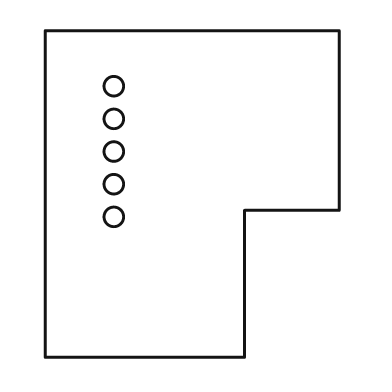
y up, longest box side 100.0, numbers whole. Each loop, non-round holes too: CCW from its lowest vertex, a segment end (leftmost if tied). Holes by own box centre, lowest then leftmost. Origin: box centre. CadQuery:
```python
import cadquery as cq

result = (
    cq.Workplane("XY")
    .moveTo(-45.0, -50.0)
    .lineTo(16.0, -50.0)
    .lineTo(16.0, -5.0)
    .lineTo(45.0, -5.0)
    .lineTo(45.0, 50.0)
    .lineTo(-45.0, 50.0)
    .close()
    .moveTo(-24.0, -7.0)
    .circle(3.0)
    .moveTo(-24.0, 3.0)
    .circle(3.0)
    .moveTo(-24.0, 13.0)
    .circle(3.0)
    .moveTo(-24.0, 23.0)
    .circle(3.0)
    .moveTo(-24.0, 33.0)
    .circle(3.0)
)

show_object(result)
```